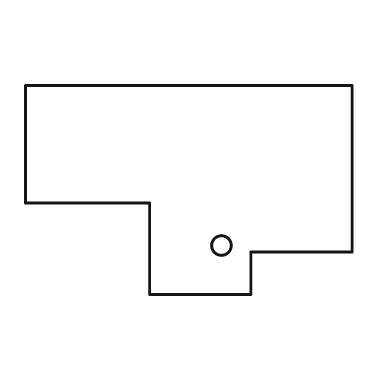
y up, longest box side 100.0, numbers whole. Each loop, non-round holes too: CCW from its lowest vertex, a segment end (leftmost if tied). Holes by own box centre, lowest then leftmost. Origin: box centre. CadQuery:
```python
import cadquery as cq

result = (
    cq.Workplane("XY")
    .moveTo(-12.0, -32.0)
    .lineTo(19.0, -32.0)
    .lineTo(19.0, -19.0)
    .lineTo(50.0, -19.0)
    .lineTo(50.0, 32.0)
    .lineTo(-50.0, 32.0)
    .lineTo(-50.0, -4.0)
    .lineTo(-12.0, -4.0)
    .close()
    .moveTo(10.0, -17.0)
    .circle(3.0)
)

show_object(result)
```